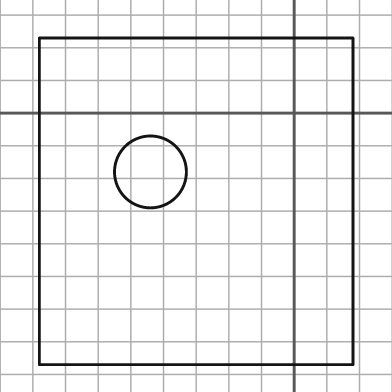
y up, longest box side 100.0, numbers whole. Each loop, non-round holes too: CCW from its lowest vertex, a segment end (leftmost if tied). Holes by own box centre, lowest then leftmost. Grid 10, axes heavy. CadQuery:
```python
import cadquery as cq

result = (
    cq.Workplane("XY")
    .moveTo(-78.0, -77.0)
    .lineTo(18.0, -77.0)
    .lineTo(18.0, 23.0)
    .lineTo(-78.0, 23.0)
    .close()
    .moveTo(-44.0, -18.0)
    .circle(11.0)
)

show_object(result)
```